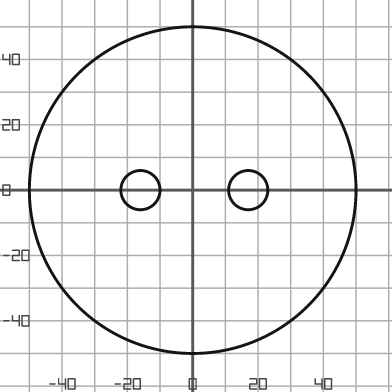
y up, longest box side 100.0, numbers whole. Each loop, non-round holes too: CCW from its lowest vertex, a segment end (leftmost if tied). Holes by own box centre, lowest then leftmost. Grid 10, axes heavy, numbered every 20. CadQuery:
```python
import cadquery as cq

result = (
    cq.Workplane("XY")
    .moveTo(0.0, 0.0)
    .circle(50.0)
    .moveTo(-16.0, 0.0)
    .circle(6.0)
    .moveTo(17.0, 0.0)
    .circle(6.0)
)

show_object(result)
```